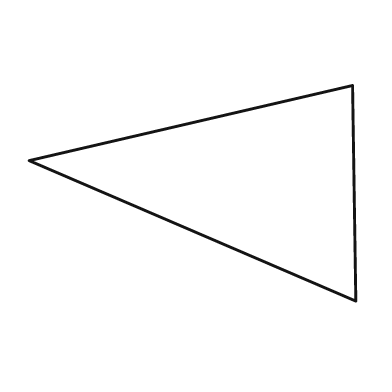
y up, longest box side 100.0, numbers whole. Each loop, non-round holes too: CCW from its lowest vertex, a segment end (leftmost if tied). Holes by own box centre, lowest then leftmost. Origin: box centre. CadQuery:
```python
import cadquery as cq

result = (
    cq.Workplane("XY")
    .moveTo(50.0, -33.0)
    .lineTo(49.0, 33.0)
    .lineTo(-50.0, 10.0)
    .close()
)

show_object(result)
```